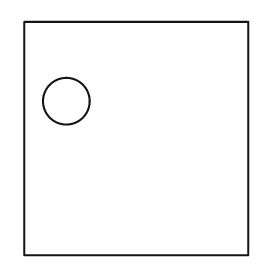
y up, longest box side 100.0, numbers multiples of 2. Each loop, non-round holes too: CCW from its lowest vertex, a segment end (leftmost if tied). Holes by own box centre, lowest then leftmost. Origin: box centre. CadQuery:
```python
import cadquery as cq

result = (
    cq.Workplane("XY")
    .moveTo(-48.0, -50.0)
    .lineTo(48.0, -50.0)
    .lineTo(48.0, 50.0)
    .lineTo(-48.0, 50.0)
    .close()
    .moveTo(-30.0, 16.0)
    .circle(10.0)
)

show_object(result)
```